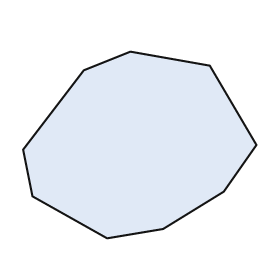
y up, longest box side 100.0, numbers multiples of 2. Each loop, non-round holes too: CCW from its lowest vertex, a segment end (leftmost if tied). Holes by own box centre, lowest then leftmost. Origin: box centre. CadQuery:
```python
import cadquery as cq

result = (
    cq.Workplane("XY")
    .moveTo(-14.0, -40.0)
    .lineTo(10.0, -36.0)
    .lineTo(36.0, -20.0)
    .lineTo(50.0, 0.0)
    .lineTo(30.0, 34.0)
    .lineTo(-4.0, 40.0)
    .lineTo(-24.0, 32.0)
    .lineTo(-50.0, -2.0)
    .lineTo(-46.0, -22.0)
    .close()
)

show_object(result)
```